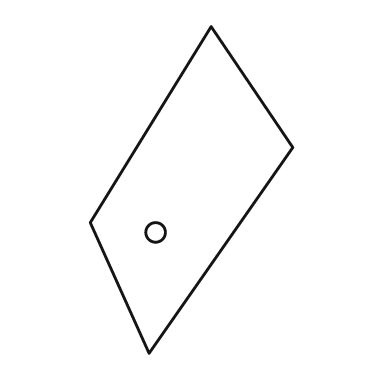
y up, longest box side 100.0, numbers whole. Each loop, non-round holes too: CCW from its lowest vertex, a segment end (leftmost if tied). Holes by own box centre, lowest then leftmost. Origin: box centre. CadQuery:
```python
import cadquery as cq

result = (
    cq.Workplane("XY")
    .moveTo(-13.0, -50.0)
    .lineTo(31.0, 13.0)
    .lineTo(6.0, 50.0)
    .lineTo(-31.0, -10.0)
    .close()
    .moveTo(-11.0, -13.0)
    .circle(3.0)
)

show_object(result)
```